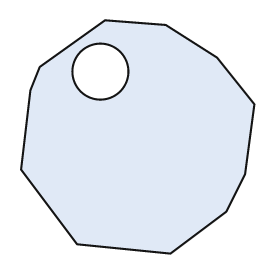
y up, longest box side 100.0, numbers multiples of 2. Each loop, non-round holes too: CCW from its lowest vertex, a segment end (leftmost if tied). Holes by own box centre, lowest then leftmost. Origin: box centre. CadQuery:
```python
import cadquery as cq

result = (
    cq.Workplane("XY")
    .moveTo(14.0, -50.0)
    .lineTo(38.0, -32.0)
    .lineTo(46.0, -16.0)
    .lineTo(50.0, 14.0)
    .lineTo(34.0, 34.0)
    .lineTo(12.0, 48.0)
    .lineTo(-14.0, 50.0)
    .lineTo(-42.0, 30.0)
    .lineTo(-46.0, 20.0)
    .lineTo(-50.0, -14.0)
    .lineTo(-26.0, -46.0)
    .close()
    .moveTo(-16.0, 28.0)
    .circle(12.0)
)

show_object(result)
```